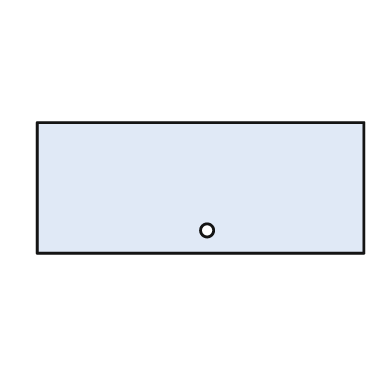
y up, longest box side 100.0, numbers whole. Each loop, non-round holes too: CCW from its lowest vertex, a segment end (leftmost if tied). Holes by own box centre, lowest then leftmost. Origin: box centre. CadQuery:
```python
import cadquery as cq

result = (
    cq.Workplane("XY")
    .moveTo(-50.0, -20.0)
    .lineTo(50.0, -20.0)
    .lineTo(50.0, 20.0)
    .lineTo(-50.0, 20.0)
    .close()
    .moveTo(2.0, -13.0)
    .circle(2.0)
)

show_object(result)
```